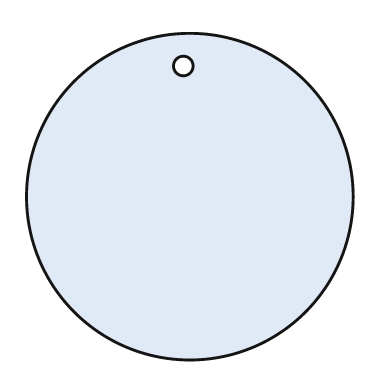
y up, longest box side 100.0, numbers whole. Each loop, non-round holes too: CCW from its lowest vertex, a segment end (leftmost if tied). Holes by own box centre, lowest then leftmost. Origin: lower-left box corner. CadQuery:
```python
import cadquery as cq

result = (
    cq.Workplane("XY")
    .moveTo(50.0, 50.0)
    .circle(50.0)
    .moveTo(48.0, 90.0)
    .circle(3.0)
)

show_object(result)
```